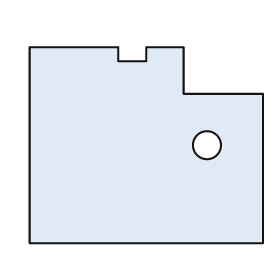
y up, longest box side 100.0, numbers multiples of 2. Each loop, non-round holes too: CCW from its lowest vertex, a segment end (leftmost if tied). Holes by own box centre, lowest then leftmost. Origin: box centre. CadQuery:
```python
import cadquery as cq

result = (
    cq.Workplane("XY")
    .moveTo(-50.0, -42.0)
    .lineTo(50.0, -42.0)
    .lineTo(50.0, 22.0)
    .lineTo(16.0, 22.0)
    .lineTo(16.0, 42.0)
    .lineTo(0.0, 42.0)
    .lineTo(0.0, 36.0)
    .lineTo(-12.0, 36.0)
    .lineTo(-12.0, 42.0)
    .lineTo(-50.0, 42.0)
    .close()
    .moveTo(26.0, 0.0)
    .circle(6.0)
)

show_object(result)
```